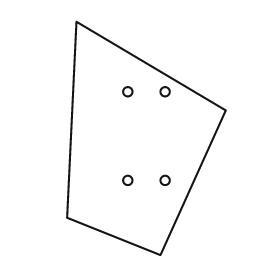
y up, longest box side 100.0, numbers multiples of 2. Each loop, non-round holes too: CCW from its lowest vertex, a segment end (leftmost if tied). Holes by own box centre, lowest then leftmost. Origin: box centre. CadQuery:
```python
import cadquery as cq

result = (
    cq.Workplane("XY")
    .moveTo(6.0, -50.0)
    .lineTo(34.0, 12.0)
    .lineTo(-30.0, 50.0)
    .lineTo(-34.0, -34.0)
    .close()
    .moveTo(-8.0, -18.0)
    .circle(2.0)
    .moveTo(8.0, -18.0)
    .circle(2.0)
    .moveTo(-8.0, 20.0)
    .circle(2.0)
    .moveTo(8.0, 20.0)
    .circle(2.0)
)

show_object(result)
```